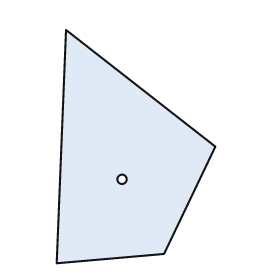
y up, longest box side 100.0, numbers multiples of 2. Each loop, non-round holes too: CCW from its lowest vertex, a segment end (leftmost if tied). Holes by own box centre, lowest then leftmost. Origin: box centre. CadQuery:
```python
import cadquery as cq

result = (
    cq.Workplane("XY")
    .moveTo(-34.0, -50.0)
    .lineTo(12.0, -46.0)
    .lineTo(34.0, 0.0)
    .lineTo(-30.0, 50.0)
    .close()
    .moveTo(-6.0, -14.0)
    .circle(2.0)
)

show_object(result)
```